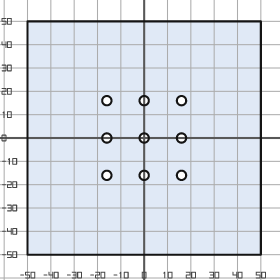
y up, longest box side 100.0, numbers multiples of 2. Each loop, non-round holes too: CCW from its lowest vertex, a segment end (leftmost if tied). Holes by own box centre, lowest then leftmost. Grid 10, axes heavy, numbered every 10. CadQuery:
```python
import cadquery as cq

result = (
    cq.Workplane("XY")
    .moveTo(-50.0, -50.0)
    .lineTo(50.0, -50.0)
    .lineTo(50.0, 50.0)
    .lineTo(-50.0, 50.0)
    .close()
    .moveTo(-16.0, -16.0)
    .circle(2.0)
    .moveTo(0.0, -16.0)
    .circle(2.0)
    .moveTo(16.0, -16.0)
    .circle(2.0)
    .moveTo(-16.0, 0.0)
    .circle(2.0)
    .moveTo(0.0, 0.0)
    .circle(2.0)
    .moveTo(16.0, 0.0)
    .circle(2.0)
    .moveTo(-16.0, 16.0)
    .circle(2.0)
    .moveTo(0.0, 16.0)
    .circle(2.0)
    .moveTo(16.0, 16.0)
    .circle(2.0)
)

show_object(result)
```